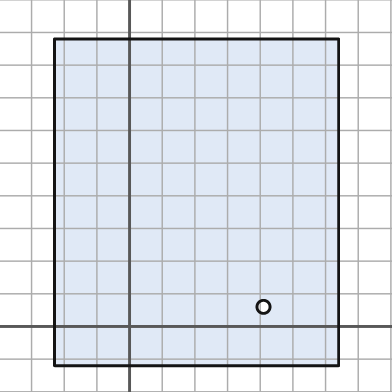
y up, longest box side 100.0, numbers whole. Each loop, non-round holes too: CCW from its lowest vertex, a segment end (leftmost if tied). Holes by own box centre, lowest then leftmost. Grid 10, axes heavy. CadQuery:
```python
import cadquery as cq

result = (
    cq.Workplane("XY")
    .moveTo(-23.0, -12.0)
    .lineTo(64.0, -12.0)
    .lineTo(64.0, 88.0)
    .lineTo(-23.0, 88.0)
    .close()
    .moveTo(41.0, 6.0)
    .circle(2.0)
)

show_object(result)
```